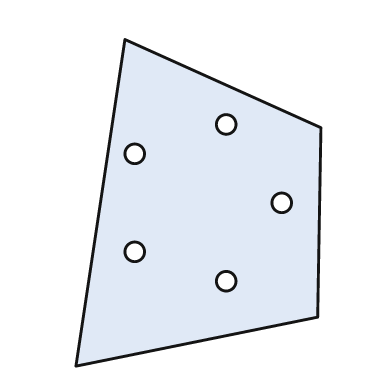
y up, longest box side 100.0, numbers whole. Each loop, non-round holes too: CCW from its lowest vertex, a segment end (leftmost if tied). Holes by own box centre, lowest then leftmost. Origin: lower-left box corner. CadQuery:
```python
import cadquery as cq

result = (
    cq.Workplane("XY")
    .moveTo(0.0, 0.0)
    .lineTo(74.0, 15.0)
    .lineTo(75.0, 73.0)
    .lineTo(15.0, 100.0)
    .close()
    .moveTo(46.0, 26.0)
    .circle(3.0)
    .moveTo(18.0, 35.0)
    .circle(3.0)
    .moveTo(63.0, 50.0)
    .circle(3.0)
    .moveTo(18.0, 65.0)
    .circle(3.0)
    .moveTo(46.0, 74.0)
    .circle(3.0)
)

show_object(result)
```